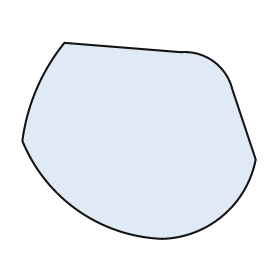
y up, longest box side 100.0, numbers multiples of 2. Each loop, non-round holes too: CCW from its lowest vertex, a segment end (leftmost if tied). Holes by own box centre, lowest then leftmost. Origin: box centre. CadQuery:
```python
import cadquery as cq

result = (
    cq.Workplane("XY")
    .moveTo(10.0, -42.0)
    .threePointArc((36.0, -32.0), (50.0, -8.0))
    .lineTo(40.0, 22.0)
    .threePointArc((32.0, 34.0), (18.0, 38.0))
    .lineTo(-32.0, 42.0)
    .threePointArc((-44.0, 22.0), (-50.0, 0.0))
    .threePointArc((-26.0, -30.0), (10.0, -42.0))
    .close()
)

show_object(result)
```